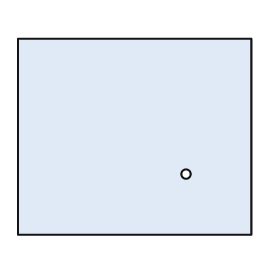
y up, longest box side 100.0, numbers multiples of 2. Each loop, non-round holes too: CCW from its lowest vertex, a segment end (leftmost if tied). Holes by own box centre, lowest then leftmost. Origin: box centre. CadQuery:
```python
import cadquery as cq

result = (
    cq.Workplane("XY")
    .moveTo(-50.0, -42.0)
    .lineTo(50.0, -42.0)
    .lineTo(50.0, 42.0)
    .lineTo(-50.0, 42.0)
    .close()
    .moveTo(22.0, -16.0)
    .circle(2.0)
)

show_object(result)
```